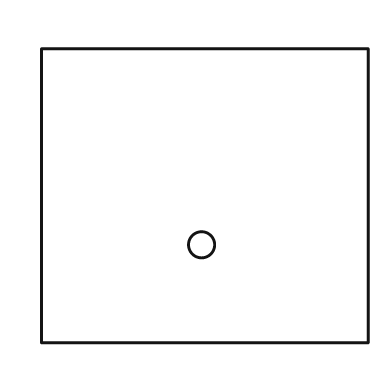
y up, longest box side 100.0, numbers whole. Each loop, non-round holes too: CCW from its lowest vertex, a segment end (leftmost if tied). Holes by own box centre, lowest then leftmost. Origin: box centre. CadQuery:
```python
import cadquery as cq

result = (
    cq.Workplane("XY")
    .moveTo(-50.0, -45.0)
    .lineTo(50.0, -45.0)
    .lineTo(50.0, 45.0)
    .lineTo(-50.0, 45.0)
    .close()
    .moveTo(-1.0, -15.0)
    .circle(4.0)
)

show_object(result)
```